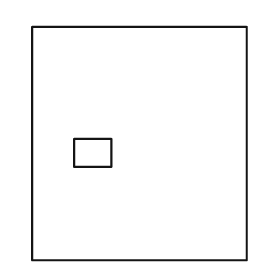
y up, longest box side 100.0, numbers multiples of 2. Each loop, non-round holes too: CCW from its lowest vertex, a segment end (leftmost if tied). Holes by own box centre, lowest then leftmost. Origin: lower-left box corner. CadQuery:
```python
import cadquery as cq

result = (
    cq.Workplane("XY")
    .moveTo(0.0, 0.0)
    .lineTo(92.0, 0.0)
    .lineTo(92.0, 100.0)
    .lineTo(0.0, 100.0)
    .close()
    .moveTo(18.0, 40.0)
    .lineTo(34.0, 40.0)
    .lineTo(34.0, 52.0)
    .lineTo(18.0, 52.0)
    .close()
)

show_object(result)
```